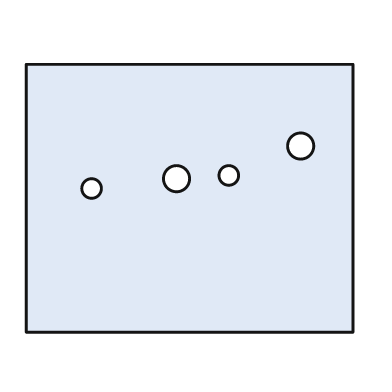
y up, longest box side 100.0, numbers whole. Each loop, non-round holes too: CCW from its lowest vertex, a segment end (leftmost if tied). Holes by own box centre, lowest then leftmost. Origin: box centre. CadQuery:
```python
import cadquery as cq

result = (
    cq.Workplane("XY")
    .moveTo(-50.0, -41.0)
    .lineTo(50.0, -41.0)
    .lineTo(50.0, 41.0)
    .lineTo(-50.0, 41.0)
    .close()
    .moveTo(-30.0, 3.0)
    .circle(3.0)
    .moveTo(-4.0, 6.0)
    .circle(4.0)
    .moveTo(12.0, 7.0)
    .circle(3.0)
    .moveTo(34.0, 16.0)
    .circle(4.0)
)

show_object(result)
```